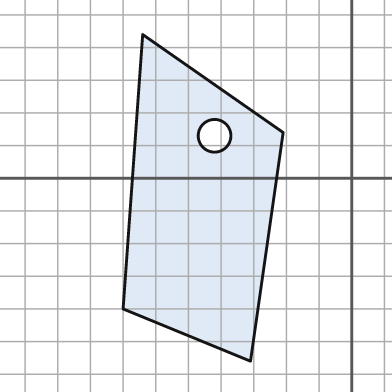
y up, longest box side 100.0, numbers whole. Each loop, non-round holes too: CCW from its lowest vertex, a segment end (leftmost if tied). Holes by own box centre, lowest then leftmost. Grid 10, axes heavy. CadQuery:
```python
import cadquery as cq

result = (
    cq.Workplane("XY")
    .moveTo(-31.0, -56.0)
    .lineTo(-21.0, 14.0)
    .lineTo(-64.0, 44.0)
    .lineTo(-70.0, -40.0)
    .close()
    .moveTo(-42.0, 13.0)
    .circle(5.0)
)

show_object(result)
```